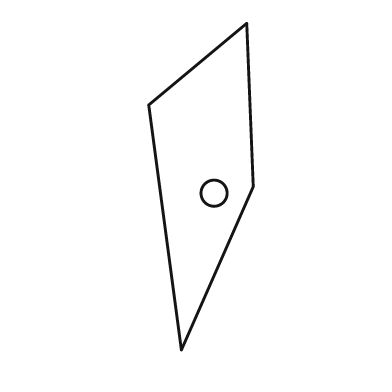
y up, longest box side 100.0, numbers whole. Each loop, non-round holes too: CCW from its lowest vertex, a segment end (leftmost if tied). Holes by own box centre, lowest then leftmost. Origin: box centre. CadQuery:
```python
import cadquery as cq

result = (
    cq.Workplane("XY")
    .moveTo(-6.0, -50.0)
    .lineTo(16.0, 0.0)
    .lineTo(14.0, 50.0)
    .lineTo(-16.0, 25.0)
    .close()
    .moveTo(4.0, -2.0)
    .circle(4.0)
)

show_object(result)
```